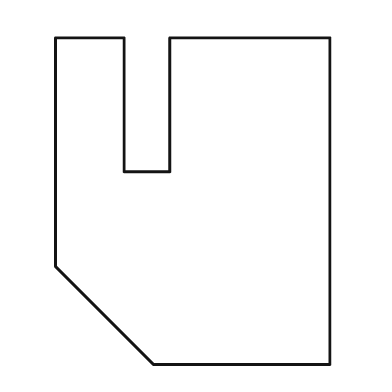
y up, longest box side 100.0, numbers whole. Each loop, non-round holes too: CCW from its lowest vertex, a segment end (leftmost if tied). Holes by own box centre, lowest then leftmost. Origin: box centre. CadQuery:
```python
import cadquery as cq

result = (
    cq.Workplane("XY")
    .moveTo(-12.0, -50.0)
    .lineTo(42.0, -50.0)
    .lineTo(42.0, 50.0)
    .lineTo(-7.0, 50.0)
    .lineTo(-7.0, 9.0)
    .lineTo(-21.0, 9.0)
    .lineTo(-21.0, 50.0)
    .lineTo(-42.0, 50.0)
    .lineTo(-42.0, -20.0)
    .close()
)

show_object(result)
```